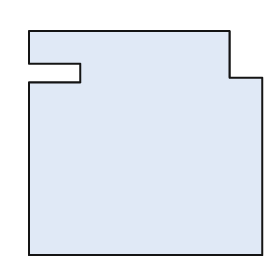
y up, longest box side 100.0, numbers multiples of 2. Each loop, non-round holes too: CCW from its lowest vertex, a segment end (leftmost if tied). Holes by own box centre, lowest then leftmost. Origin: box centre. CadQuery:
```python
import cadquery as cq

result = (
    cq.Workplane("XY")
    .moveTo(-50.0, -48.0)
    .lineTo(50.0, -48.0)
    .lineTo(50.0, 28.0)
    .lineTo(36.0, 28.0)
    .lineTo(36.0, 48.0)
    .lineTo(-50.0, 48.0)
    .lineTo(-50.0, 34.0)
    .lineTo(-28.0, 34.0)
    .lineTo(-28.0, 26.0)
    .lineTo(-50.0, 26.0)
    .close()
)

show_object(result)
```